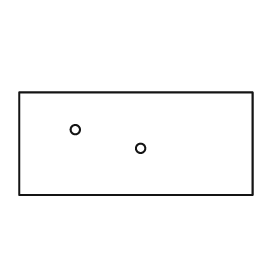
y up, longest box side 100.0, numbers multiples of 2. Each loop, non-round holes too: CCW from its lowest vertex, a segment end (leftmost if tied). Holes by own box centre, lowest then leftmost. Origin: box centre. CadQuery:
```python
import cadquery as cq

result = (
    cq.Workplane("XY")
    .moveTo(-50.0, -22.0)
    .lineTo(50.0, -22.0)
    .lineTo(50.0, 22.0)
    .lineTo(-50.0, 22.0)
    .close()
    .moveTo(2.0, -2.0)
    .circle(2.0)
    .moveTo(-26.0, 6.0)
    .circle(2.0)
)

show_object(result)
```